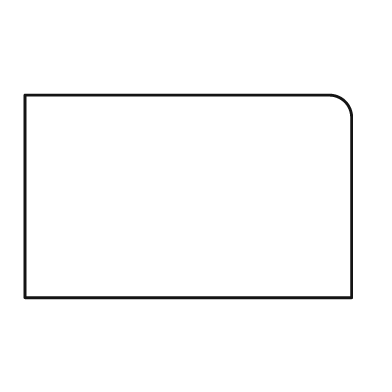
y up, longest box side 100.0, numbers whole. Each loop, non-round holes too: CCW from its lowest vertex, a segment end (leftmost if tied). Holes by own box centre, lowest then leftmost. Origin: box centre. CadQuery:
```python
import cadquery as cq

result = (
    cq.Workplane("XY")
    .moveTo(-50.0, -31.0)
    .lineTo(50.0, -31.0)
    .lineTo(50.0, 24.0)
    .threePointArc((48.0, 29.0), (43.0, 31.0))
    .lineTo(-50.0, 31.0)
    .close()
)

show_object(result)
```